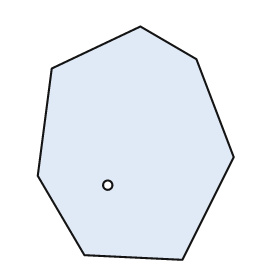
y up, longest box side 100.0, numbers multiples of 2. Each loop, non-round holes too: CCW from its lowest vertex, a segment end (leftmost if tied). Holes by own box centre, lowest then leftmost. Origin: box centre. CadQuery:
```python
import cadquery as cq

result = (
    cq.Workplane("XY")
    .moveTo(20.0, -50.0)
    .lineTo(42.0, -6.0)
    .lineTo(26.0, 36.0)
    .lineTo(2.0, 50.0)
    .lineTo(-36.0, 32.0)
    .lineTo(-42.0, -14.0)
    .lineTo(-22.0, -48.0)
    .close()
    .moveTo(-12.0, -18.0)
    .circle(2.0)
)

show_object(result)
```